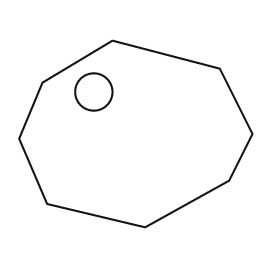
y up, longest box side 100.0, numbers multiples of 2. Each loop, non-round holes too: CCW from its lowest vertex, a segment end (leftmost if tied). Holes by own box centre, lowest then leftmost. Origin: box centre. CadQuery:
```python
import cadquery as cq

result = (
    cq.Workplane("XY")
    .moveTo(4.0, -40.0)
    .lineTo(40.0, -20.0)
    .lineTo(50.0, 0.0)
    .lineTo(36.0, 28.0)
    .lineTo(-10.0, 40.0)
    .lineTo(-40.0, 22.0)
    .lineTo(-50.0, -2.0)
    .lineTo(-38.0, -30.0)
    .close()
    .moveTo(-18.0, 18.0)
    .circle(8.0)
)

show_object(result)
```